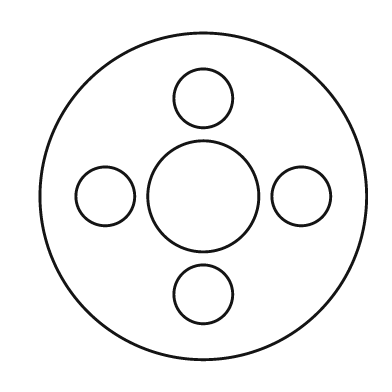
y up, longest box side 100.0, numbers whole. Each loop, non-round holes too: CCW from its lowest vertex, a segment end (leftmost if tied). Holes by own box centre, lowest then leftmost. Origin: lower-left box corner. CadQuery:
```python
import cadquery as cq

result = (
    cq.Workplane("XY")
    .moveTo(50.0, 50.0)
    .circle(50.0)
    .moveTo(50.0, 20.0)
    .circle(9.0)
    .moveTo(20.0, 50.0)
    .circle(9.0)
    .moveTo(50.0, 50.0)
    .circle(17.0)
    .moveTo(80.0, 50.0)
    .circle(9.0)
    .moveTo(50.0, 80.0)
    .circle(9.0)
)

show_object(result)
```